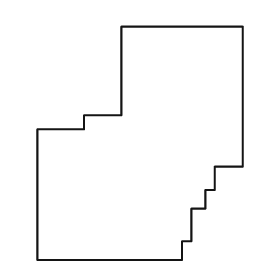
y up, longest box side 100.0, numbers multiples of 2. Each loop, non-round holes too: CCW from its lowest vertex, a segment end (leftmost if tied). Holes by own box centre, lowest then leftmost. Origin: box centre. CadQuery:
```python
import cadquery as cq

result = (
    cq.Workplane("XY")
    .moveTo(-44.0, -50.0)
    .lineTo(18.0, -50.0)
    .lineTo(18.0, -42.0)
    .lineTo(22.0, -42.0)
    .lineTo(22.0, -28.0)
    .lineTo(28.0, -28.0)
    .lineTo(28.0, -20.0)
    .lineTo(32.0, -20.0)
    .lineTo(32.0, -10.0)
    .lineTo(44.0, -10.0)
    .lineTo(44.0, 50.0)
    .lineTo(-8.0, 50.0)
    .lineTo(-8.0, 12.0)
    .lineTo(-24.0, 12.0)
    .lineTo(-24.0, 6.0)
    .lineTo(-44.0, 6.0)
    .close()
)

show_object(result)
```